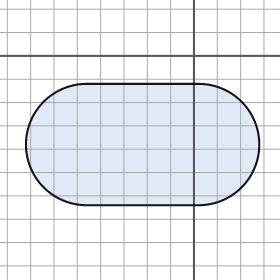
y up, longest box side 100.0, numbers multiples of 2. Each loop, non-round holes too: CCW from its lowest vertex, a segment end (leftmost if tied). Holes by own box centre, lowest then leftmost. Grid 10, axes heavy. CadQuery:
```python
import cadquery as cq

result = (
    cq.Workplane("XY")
    .moveTo(-46.0, -64.0)
    .lineTo(2.0, -64.0)
    .threePointArc((28.0, -38.0), (2.0, -12.0))
    .lineTo(-46.0, -12.0)
    .threePointArc((-72.0, -38.0), (-46.0, -64.0))
    .close()
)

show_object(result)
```